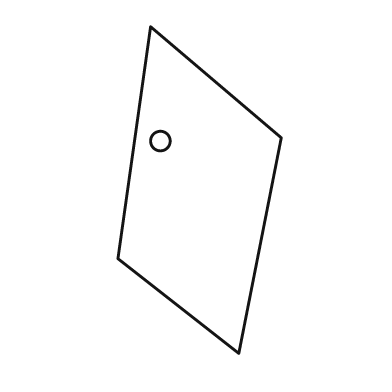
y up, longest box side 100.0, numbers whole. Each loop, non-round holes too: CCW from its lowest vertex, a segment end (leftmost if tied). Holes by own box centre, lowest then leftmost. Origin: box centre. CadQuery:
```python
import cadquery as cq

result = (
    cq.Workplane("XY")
    .moveTo(12.0, -50.0)
    .lineTo(25.0, 16.0)
    .lineTo(-15.0, 50.0)
    .lineTo(-25.0, -21.0)
    .close()
    .moveTo(-12.0, 15.0)
    .circle(3.0)
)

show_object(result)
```